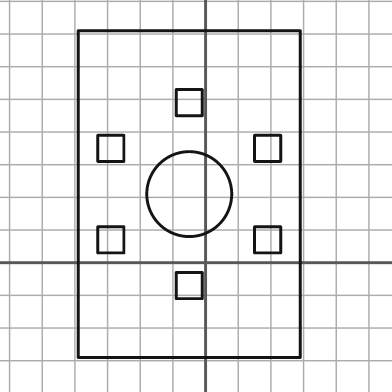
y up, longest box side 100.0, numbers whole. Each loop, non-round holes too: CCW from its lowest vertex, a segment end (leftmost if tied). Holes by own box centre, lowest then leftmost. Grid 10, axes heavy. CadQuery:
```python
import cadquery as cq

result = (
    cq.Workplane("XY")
    .moveTo(-39.0, -29.0)
    .lineTo(29.0, -29.0)
    .lineTo(29.0, 71.0)
    .lineTo(-39.0, 71.0)
    .close()
    .moveTo(-9.0, -11.0)
    .lineTo(-1.0, -11.0)
    .lineTo(-1.0, -3.0)
    .lineTo(-9.0, -3.0)
    .close()
    .moveTo(-33.0, 3.0)
    .lineTo(-25.0, 3.0)
    .lineTo(-25.0, 11.0)
    .lineTo(-33.0, 11.0)
    .close()
    .moveTo(15.0, 3.0)
    .lineTo(23.0, 3.0)
    .lineTo(23.0, 11.0)
    .lineTo(15.0, 11.0)
    .close()
    .moveTo(-5.0, 21.0)
    .circle(13.0)
    .moveTo(-33.0, 31.0)
    .lineTo(-25.0, 31.0)
    .lineTo(-25.0, 39.0)
    .lineTo(-33.0, 39.0)
    .close()
    .moveTo(15.0, 31.0)
    .lineTo(23.0, 31.0)
    .lineTo(23.0, 39.0)
    .lineTo(15.0, 39.0)
    .close()
    .moveTo(-9.0, 45.0)
    .lineTo(-1.0, 45.0)
    .lineTo(-1.0, 53.0)
    .lineTo(-9.0, 53.0)
    .close()
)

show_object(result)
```